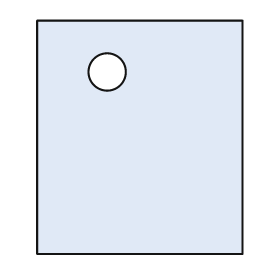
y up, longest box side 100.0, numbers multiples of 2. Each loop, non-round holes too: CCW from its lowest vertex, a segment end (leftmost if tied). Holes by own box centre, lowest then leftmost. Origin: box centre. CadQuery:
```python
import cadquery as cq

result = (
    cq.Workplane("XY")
    .moveTo(-44.0, -50.0)
    .lineTo(44.0, -50.0)
    .lineTo(44.0, 50.0)
    .lineTo(-44.0, 50.0)
    .close()
    .moveTo(-14.0, 28.0)
    .circle(8.0)
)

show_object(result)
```